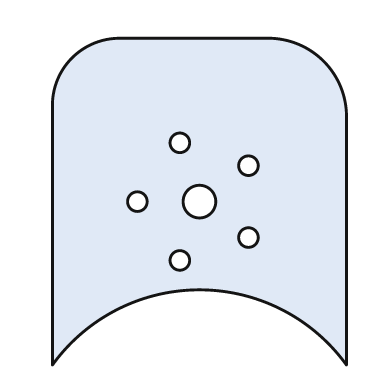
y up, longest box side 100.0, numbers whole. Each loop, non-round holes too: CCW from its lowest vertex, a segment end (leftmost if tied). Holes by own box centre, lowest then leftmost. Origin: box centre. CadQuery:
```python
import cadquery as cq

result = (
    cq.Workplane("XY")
    .moveTo(-45.0, -50.0)
    .threePointArc((0.0, -27.0), (45.0, -50.0))
    .lineTo(45.0, 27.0)
    .threePointArc((38.0, 43.0), (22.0, 50.0))
    .lineTo(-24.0, 50.0)
    .threePointArc((-39.0, 44.0), (-45.0, 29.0))
    .close()
    .moveTo(-6.0, -18.0)
    .circle(3.0)
    .moveTo(15.0, -11.0)
    .circle(3.0)
    .moveTo(-19.0, 0.0)
    .circle(3.0)
    .moveTo(0.0, 0.0)
    .circle(5.0)
    .moveTo(15.0, 11.0)
    .circle(3.0)
    .moveTo(-6.0, 18.0)
    .circle(3.0)
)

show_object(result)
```